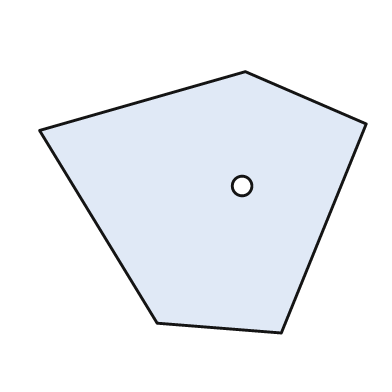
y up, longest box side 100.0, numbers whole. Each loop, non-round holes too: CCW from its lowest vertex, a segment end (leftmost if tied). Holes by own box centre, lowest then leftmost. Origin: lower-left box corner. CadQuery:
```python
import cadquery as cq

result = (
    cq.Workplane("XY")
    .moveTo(74.0, 0.0)
    .lineTo(100.0, 64.0)
    .lineTo(63.0, 80.0)
    .lineTo(0.0, 62.0)
    .lineTo(36.0, 3.0)
    .close()
    .moveTo(62.0, 45.0)
    .circle(3.0)
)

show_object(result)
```